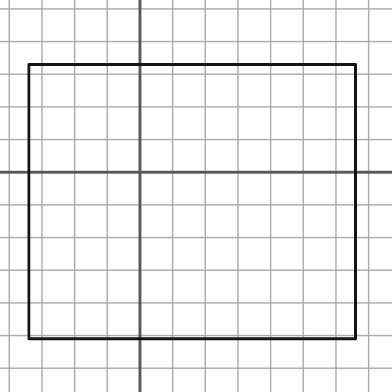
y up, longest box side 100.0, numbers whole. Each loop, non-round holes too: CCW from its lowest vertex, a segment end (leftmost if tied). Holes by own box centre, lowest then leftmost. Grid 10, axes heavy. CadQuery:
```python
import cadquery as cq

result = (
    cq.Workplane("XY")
    .moveTo(-34.0, -51.0)
    .lineTo(66.0, -51.0)
    .lineTo(66.0, 33.0)
    .lineTo(-34.0, 33.0)
    .close()
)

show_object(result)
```